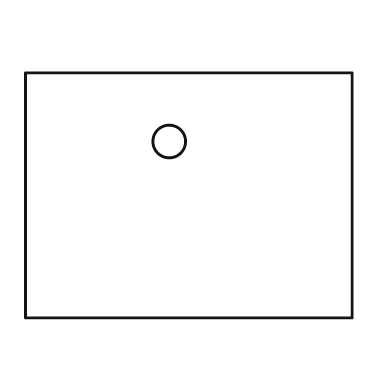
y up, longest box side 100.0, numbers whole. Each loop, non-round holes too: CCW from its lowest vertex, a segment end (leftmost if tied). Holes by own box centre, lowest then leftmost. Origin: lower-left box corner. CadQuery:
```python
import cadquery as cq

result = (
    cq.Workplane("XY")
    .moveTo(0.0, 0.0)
    .lineTo(100.0, 0.0)
    .lineTo(100.0, 75.0)
    .lineTo(0.0, 75.0)
    .close()
    .moveTo(44.0, 54.0)
    .circle(5.0)
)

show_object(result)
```